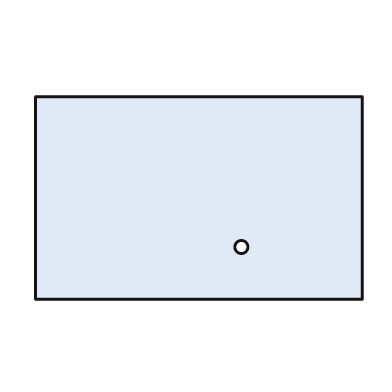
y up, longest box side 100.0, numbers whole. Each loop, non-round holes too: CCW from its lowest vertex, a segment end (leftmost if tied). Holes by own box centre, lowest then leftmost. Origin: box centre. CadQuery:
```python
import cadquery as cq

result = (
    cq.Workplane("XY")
    .moveTo(-50.0, -31.0)
    .lineTo(50.0, -31.0)
    .lineTo(50.0, 31.0)
    .lineTo(-50.0, 31.0)
    .close()
    .moveTo(13.0, -15.0)
    .circle(2.0)
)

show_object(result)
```